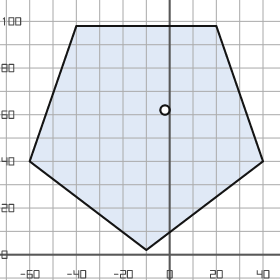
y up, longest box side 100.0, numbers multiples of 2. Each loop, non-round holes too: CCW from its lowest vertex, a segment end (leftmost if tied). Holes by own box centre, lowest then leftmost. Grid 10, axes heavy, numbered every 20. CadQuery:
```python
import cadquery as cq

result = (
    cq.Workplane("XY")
    .moveTo(-10.0, 2.0)
    .lineTo(40.0, 40.0)
    .lineTo(20.0, 98.0)
    .lineTo(-40.0, 98.0)
    .lineTo(-60.0, 40.0)
    .close()
    .moveTo(-2.0, 62.0)
    .circle(2.0)
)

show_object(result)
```